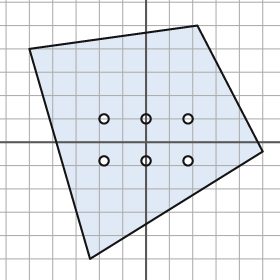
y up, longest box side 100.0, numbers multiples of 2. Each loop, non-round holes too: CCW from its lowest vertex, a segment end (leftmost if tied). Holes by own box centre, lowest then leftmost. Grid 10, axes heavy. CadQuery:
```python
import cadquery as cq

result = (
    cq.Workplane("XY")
    .moveTo(-24.0, -50.0)
    .lineTo(50.0, -4.0)
    .lineTo(22.0, 50.0)
    .lineTo(-50.0, 40.0)
    .close()
    .moveTo(-18.0, -8.0)
    .circle(2.0)
    .moveTo(0.0, -8.0)
    .circle(2.0)
    .moveTo(18.0, -8.0)
    .circle(2.0)
    .moveTo(-18.0, 10.0)
    .circle(2.0)
    .moveTo(0.0, 10.0)
    .circle(2.0)
    .moveTo(18.0, 10.0)
    .circle(2.0)
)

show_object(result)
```